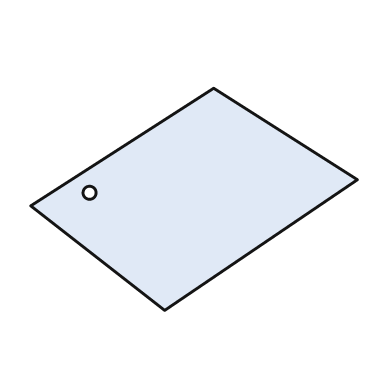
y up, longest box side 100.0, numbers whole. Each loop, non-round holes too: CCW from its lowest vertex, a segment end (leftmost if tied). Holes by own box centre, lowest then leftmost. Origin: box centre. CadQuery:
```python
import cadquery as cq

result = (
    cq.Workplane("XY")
    .moveTo(-9.0, -34.0)
    .lineTo(50.0, 6.0)
    .lineTo(6.0, 34.0)
    .lineTo(-50.0, -2.0)
    .close()
    .moveTo(-32.0, 2.0)
    .circle(2.0)
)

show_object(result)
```